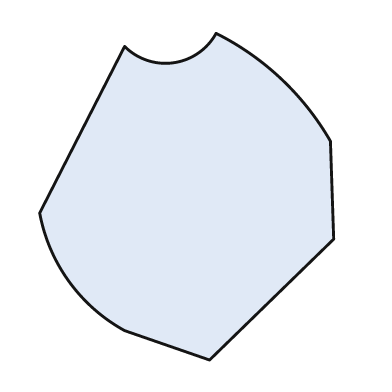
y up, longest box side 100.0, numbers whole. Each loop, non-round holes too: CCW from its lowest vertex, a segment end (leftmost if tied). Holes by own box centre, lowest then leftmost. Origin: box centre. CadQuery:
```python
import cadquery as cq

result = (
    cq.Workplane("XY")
    .moveTo(7.0, -50.0)
    .lineTo(45.0, -13.0)
    .lineTo(44.0, 17.0)
    .threePointArc((29.0, 36.0), (9.0, 50.0))
    .threePointArc((-4.0, 41.0), (-19.0, 46.0))
    .lineTo(-45.0, -5.0)
    .threePointArc((-36.0, -26.0), (-19.0, -41.0))
    .close()
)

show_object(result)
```